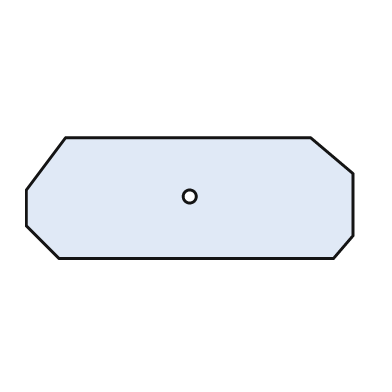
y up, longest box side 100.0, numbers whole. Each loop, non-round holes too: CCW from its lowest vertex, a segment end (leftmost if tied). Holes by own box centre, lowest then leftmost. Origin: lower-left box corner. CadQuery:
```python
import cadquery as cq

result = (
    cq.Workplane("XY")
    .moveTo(10.0, 0.0)
    .lineTo(94.0, 0.0)
    .lineTo(100.0, 7.0)
    .lineTo(100.0, 26.0)
    .lineTo(87.0, 37.0)
    .lineTo(12.0, 37.0)
    .lineTo(0.0, 21.0)
    .lineTo(0.0, 10.0)
    .close()
    .moveTo(50.0, 19.0)
    .circle(2.0)
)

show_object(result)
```